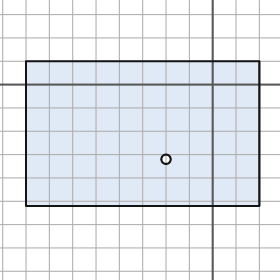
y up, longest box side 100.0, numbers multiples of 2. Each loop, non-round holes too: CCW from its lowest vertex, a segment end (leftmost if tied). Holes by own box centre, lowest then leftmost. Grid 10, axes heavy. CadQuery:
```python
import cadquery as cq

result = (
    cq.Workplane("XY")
    .moveTo(-80.0, -52.0)
    .lineTo(20.0, -52.0)
    .lineTo(20.0, 10.0)
    .lineTo(-80.0, 10.0)
    .close()
    .moveTo(-20.0, -32.0)
    .circle(2.0)
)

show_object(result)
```